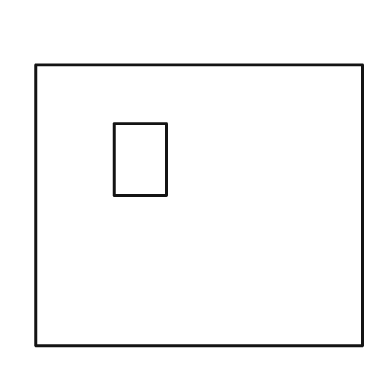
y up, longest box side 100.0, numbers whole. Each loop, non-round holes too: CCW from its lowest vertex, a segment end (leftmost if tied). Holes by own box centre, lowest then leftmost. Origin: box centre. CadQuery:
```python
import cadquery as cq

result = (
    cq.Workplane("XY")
    .moveTo(-50.0, -43.0)
    .lineTo(50.0, -43.0)
    .lineTo(50.0, 43.0)
    .lineTo(-50.0, 43.0)
    .close()
    .moveTo(-26.0, 3.0)
    .lineTo(-10.0, 3.0)
    .lineTo(-10.0, 25.0)
    .lineTo(-26.0, 25.0)
    .close()
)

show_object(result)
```